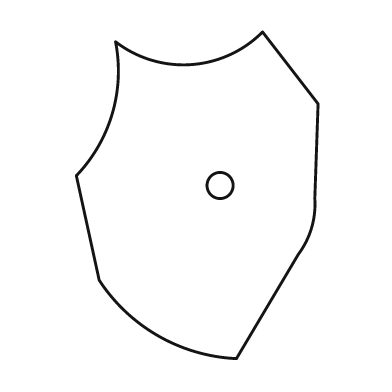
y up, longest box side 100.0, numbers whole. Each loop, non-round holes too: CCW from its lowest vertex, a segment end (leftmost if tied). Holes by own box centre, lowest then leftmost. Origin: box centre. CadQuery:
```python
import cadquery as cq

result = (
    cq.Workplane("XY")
    .moveTo(12.0, -50.0)
    .lineTo(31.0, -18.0)
    .threePointArc((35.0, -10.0), (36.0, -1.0))
    .lineTo(37.0, 28.0)
    .lineTo(20.0, 50.0)
    .threePointArc((-2.0, 40.0), (-25.0, 47.0))
    .threePointArc((-26.0, 25.0), (-37.0, 6.0))
    .lineTo(-30.0, -26.0)
    .threePointArc((-12.0, -43.0), (12.0, -50.0))
    .close()
    .moveTo(7.0, 3.0)
    .circle(4.0)
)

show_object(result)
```